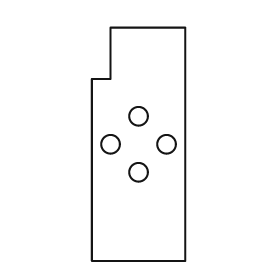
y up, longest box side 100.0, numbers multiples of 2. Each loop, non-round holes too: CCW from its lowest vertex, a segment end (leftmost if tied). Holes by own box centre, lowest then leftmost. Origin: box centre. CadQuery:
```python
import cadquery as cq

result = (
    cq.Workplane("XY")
    .moveTo(-20.0, -50.0)
    .lineTo(20.0, -50.0)
    .lineTo(20.0, 50.0)
    .lineTo(-12.0, 50.0)
    .lineTo(-12.0, 28.0)
    .lineTo(-20.0, 28.0)
    .close()
    .moveTo(0.0, -12.0)
    .circle(4.0)
    .moveTo(-12.0, 0.0)
    .circle(4.0)
    .moveTo(12.0, 0.0)
    .circle(4.0)
    .moveTo(0.0, 12.0)
    .circle(4.0)
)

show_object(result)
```